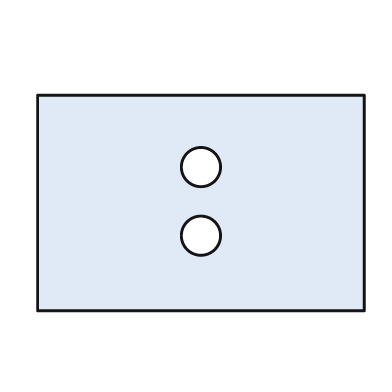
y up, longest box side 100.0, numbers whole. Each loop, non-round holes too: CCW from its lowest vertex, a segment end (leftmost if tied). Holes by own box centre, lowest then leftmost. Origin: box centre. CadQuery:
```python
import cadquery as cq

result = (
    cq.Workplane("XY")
    .moveTo(-50.0, -33.0)
    .lineTo(50.0, -33.0)
    .lineTo(50.0, 33.0)
    .lineTo(-50.0, 33.0)
    .close()
    .moveTo(0.0, -10.0)
    .circle(6.0)
    .moveTo(0.0, 11.0)
    .circle(6.0)
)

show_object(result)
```